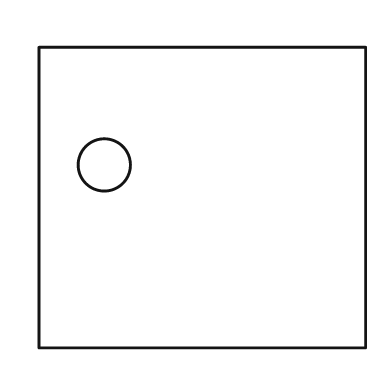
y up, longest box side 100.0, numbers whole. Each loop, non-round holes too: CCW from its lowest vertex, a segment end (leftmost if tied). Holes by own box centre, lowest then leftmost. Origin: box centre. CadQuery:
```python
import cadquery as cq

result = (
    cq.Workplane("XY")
    .moveTo(-50.0, -46.0)
    .lineTo(50.0, -46.0)
    .lineTo(50.0, 46.0)
    .lineTo(-50.0, 46.0)
    .close()
    .moveTo(-30.0, 10.0)
    .circle(8.0)
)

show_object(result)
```